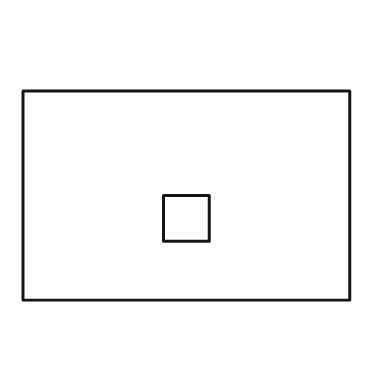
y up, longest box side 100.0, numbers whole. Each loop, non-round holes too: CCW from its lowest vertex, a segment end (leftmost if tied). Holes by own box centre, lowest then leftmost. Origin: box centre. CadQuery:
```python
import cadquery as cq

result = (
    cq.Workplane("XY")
    .moveTo(-50.0, -32.0)
    .lineTo(50.0, -32.0)
    .lineTo(50.0, 32.0)
    .lineTo(-50.0, 32.0)
    .close()
    .moveTo(-7.0, -14.0)
    .lineTo(7.0, -14.0)
    .lineTo(7.0, 0.0)
    .lineTo(-7.0, 0.0)
    .close()
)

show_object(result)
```